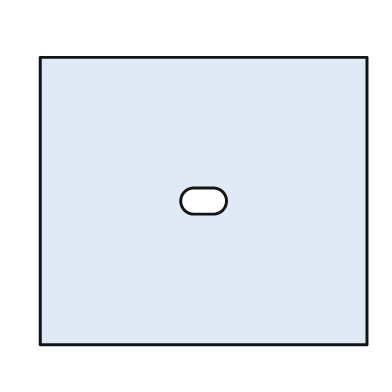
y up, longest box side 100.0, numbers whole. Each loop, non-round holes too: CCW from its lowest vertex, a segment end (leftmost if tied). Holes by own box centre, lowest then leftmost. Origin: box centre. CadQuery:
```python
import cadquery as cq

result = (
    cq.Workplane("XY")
    .moveTo(-50.0, -44.0)
    .lineTo(50.0, -44.0)
    .lineTo(50.0, 44.0)
    .lineTo(-50.0, 44.0)
    .close()
    .moveTo(-3.0, -4.0)
    .lineTo(3.0, -4.0)
    .threePointArc((7.0, 0.0), (3.0, 4.0))
    .lineTo(-3.0, 4.0)
    .threePointArc((-7.0, 0.0), (-3.0, -4.0))
    .close()
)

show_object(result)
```